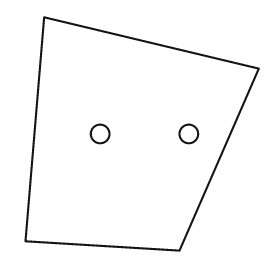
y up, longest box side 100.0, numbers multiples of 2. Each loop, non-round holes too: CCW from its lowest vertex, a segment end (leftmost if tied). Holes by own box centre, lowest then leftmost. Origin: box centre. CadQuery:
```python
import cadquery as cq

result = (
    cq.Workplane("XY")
    .moveTo(16.0, -50.0)
    .lineTo(50.0, 28.0)
    .lineTo(-42.0, 50.0)
    .lineTo(-50.0, -46.0)
    .close()
    .moveTo(-18.0, 0.0)
    .circle(4.0)
    .moveTo(20.0, 0.0)
    .circle(4.0)
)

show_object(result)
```